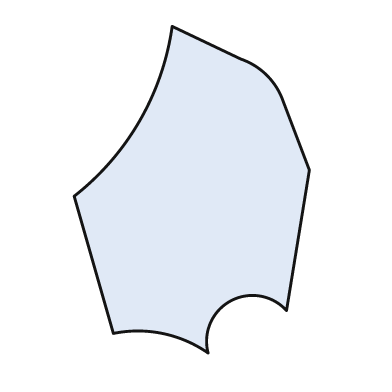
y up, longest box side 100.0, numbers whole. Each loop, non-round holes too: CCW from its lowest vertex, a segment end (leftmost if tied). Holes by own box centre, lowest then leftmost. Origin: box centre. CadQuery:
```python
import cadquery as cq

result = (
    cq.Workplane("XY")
    .moveTo(5.0, -50.0)
    .threePointArc((12.0, -34.0), (29.0, -37.0))
    .lineTo(36.0, 6.0)
    .lineTo(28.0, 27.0)
    .threePointArc((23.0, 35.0), (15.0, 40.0))
    .lineTo(-6.0, 50.0)
    .threePointArc((-16.0, 21.0), (-36.0, -2.0))
    .lineTo(-24.0, -44.0)
    .threePointArc((-9.0, -44.0), (5.0, -50.0))
    .close()
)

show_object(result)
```